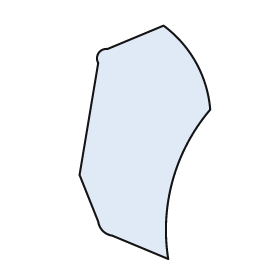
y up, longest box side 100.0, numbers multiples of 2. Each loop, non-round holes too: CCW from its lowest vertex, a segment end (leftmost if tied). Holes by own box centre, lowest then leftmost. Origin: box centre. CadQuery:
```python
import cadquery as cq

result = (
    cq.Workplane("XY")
    .moveTo(10.0, -50.0)
    .threePointArc((12.0, -16.0), (28.0, 14.0))
    .threePointArc((22.0, 34.0), (8.0, 50.0))
    .lineTo(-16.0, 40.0)
    .threePointArc((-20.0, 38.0), (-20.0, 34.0))
    .lineTo(-28.0, -14.0)
    .lineTo(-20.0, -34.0)
    .threePointArc((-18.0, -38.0), (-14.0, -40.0))
    .close()
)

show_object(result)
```